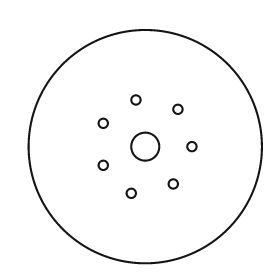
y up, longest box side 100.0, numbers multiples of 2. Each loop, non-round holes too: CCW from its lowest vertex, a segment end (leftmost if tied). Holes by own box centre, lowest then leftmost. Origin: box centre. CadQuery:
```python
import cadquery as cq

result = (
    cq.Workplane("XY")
    .moveTo(0.0, 0.0)
    .circle(50.0)
    .moveTo(-6.0, -20.0)
    .circle(2.0)
    .moveTo(12.0, -16.0)
    .circle(2.0)
    .moveTo(-18.0, -8.0)
    .circle(2.0)
    .moveTo(0.0, 0.0)
    .circle(6.0)
    .moveTo(20.0, 0.0)
    .circle(2.0)
    .moveTo(-18.0, 10.0)
    .circle(2.0)
    .moveTo(14.0, 16.0)
    .circle(2.0)
    .moveTo(-4.0, 20.0)
    .circle(2.0)
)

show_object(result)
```